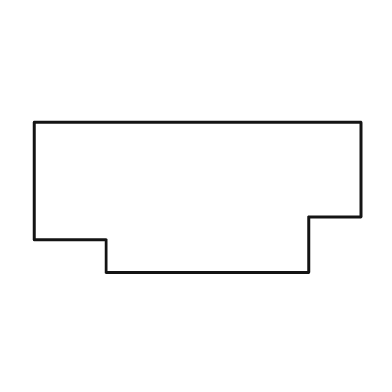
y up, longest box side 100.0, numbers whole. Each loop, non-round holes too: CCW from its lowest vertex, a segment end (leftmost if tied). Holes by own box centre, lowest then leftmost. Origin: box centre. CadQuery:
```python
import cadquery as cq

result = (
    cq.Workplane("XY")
    .moveTo(-28.0, -23.0)
    .lineTo(34.0, -23.0)
    .lineTo(34.0, -6.0)
    .lineTo(50.0, -6.0)
    .lineTo(50.0, 23.0)
    .lineTo(-50.0, 23.0)
    .lineTo(-50.0, -13.0)
    .lineTo(-28.0, -13.0)
    .close()
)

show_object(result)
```